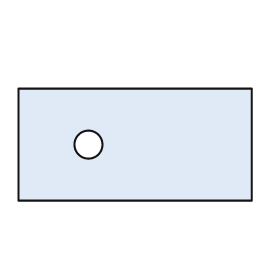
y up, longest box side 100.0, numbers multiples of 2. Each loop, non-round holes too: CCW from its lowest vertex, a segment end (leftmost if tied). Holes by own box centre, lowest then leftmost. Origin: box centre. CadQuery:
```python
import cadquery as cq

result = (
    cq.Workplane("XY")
    .moveTo(-50.0, -24.0)
    .lineTo(50.0, -24.0)
    .lineTo(50.0, 24.0)
    .lineTo(-50.0, 24.0)
    .close()
    .moveTo(-20.0, 0.0)
    .circle(6.0)
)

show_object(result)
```